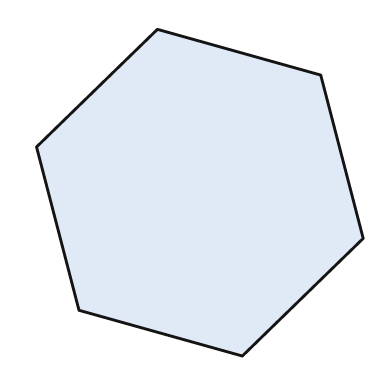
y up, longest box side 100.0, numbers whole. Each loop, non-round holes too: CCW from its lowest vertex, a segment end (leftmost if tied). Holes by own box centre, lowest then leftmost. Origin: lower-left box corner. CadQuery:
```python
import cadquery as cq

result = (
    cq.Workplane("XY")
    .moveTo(63.0, 0.0)
    .lineTo(100.0, 36.0)
    .lineTo(87.0, 86.0)
    .lineTo(37.0, 100.0)
    .lineTo(0.0, 64.0)
    .lineTo(13.0, 14.0)
    .close()
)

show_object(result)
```